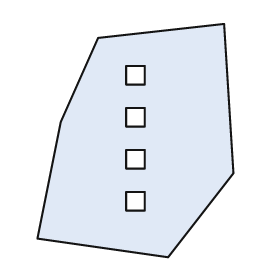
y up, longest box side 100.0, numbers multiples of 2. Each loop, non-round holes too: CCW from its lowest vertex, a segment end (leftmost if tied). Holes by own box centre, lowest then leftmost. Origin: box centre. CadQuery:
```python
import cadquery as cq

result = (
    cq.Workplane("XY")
    .moveTo(14.0, -50.0)
    .lineTo(42.0, -14.0)
    .lineTo(38.0, 50.0)
    .lineTo(-16.0, 44.0)
    .lineTo(-32.0, 8.0)
    .lineTo(-42.0, -42.0)
    .close()
    .moveTo(-4.0, -30.0)
    .lineTo(4.0, -30.0)
    .lineTo(4.0, -22.0)
    .lineTo(-4.0, -22.0)
    .close()
    .moveTo(-4.0, -12.0)
    .lineTo(4.0, -12.0)
    .lineTo(4.0, -4.0)
    .lineTo(-4.0, -4.0)
    .close()
    .moveTo(-4.0, 6.0)
    .lineTo(4.0, 6.0)
    .lineTo(4.0, 14.0)
    .lineTo(-4.0, 14.0)
    .close()
    .moveTo(-4.0, 24.0)
    .lineTo(4.0, 24.0)
    .lineTo(4.0, 32.0)
    .lineTo(-4.0, 32.0)
    .close()
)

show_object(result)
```